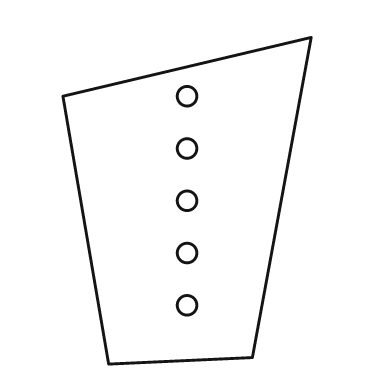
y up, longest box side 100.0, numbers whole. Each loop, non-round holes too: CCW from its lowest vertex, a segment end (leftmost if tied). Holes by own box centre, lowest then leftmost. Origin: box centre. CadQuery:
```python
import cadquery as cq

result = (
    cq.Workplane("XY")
    .moveTo(-24.0, -50.0)
    .lineTo(20.0, -48.0)
    .lineTo(38.0, 50.0)
    .lineTo(-38.0, 32.0)
    .close()
    .moveTo(0.0, -32.0)
    .circle(3.0)
    .moveTo(0.0, -16.0)
    .circle(3.0)
    .moveTo(0.0, 0.0)
    .circle(3.0)
    .moveTo(0.0, 16.0)
    .circle(3.0)
    .moveTo(0.0, 32.0)
    .circle(3.0)
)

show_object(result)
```